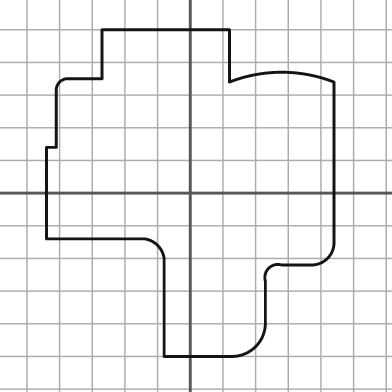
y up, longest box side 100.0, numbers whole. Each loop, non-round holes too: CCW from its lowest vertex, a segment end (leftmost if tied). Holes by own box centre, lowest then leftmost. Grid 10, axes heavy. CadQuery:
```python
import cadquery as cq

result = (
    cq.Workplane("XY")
    .moveTo(-8.0, -50.0)
    .lineTo(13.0, -50.0)
    .threePointArc((20.0, -47.0), (23.0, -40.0))
    .lineTo(23.0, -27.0)
    .threePointArc((24.0, -23.0), (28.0, -22.0))
    .lineTo(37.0, -22.0)
    .threePointArc((42.0, -20.0), (44.0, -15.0))
    .lineTo(44.0, 34.0)
    .threePointArc((28.0, 37.0), (12.0, 34.0))
    .lineTo(12.0, 50.0)
    .lineTo(-27.0, 50.0)
    .lineTo(-27.0, 35.0)
    .lineTo(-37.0, 35.0)
    .threePointArc((-40.0, 34.0), (-41.0, 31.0))
    .lineTo(-41.0, 14.0)
    .lineTo(-44.0, 14.0)
    .lineTo(-44.0, -14.0)
    .lineTo(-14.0, -14.0)
    .threePointArc((-10.0, -16.0), (-8.0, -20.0))
    .close()
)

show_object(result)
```